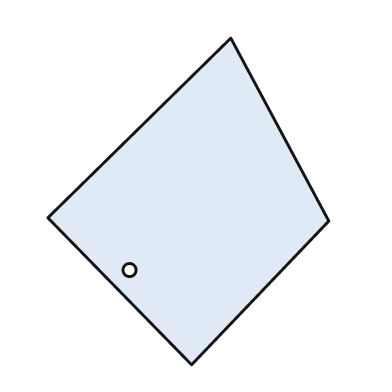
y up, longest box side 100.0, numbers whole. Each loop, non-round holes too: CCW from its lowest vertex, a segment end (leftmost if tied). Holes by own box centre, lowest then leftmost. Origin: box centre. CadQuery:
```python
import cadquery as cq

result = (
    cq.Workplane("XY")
    .moveTo(1.0, -50.0)
    .lineTo(43.0, -6.0)
    .lineTo(13.0, 50.0)
    .lineTo(-43.0, -5.0)
    .close()
    .moveTo(-18.0, -21.0)
    .circle(2.0)
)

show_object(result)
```